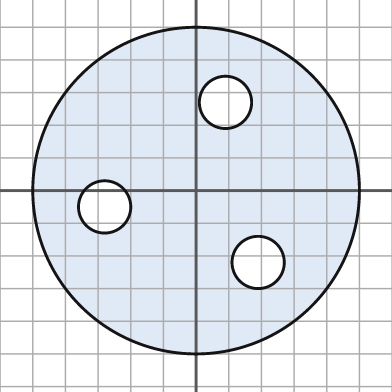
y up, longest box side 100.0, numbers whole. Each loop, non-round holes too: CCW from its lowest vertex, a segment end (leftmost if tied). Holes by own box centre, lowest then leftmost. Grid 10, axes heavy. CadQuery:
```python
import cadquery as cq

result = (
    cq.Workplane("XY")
    .moveTo(0.0, 0.0)
    .circle(50.0)
    .moveTo(19.0, -22.0)
    .circle(8.0)
    .moveTo(-28.0, -5.0)
    .circle(8.0)
    .moveTo(9.0, 27.0)
    .circle(8.0)
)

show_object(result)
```